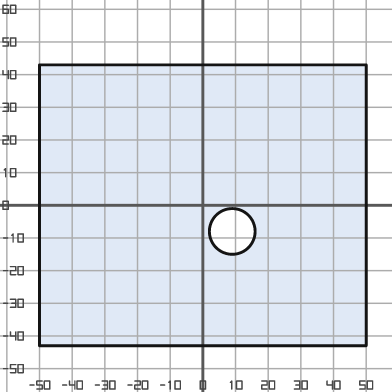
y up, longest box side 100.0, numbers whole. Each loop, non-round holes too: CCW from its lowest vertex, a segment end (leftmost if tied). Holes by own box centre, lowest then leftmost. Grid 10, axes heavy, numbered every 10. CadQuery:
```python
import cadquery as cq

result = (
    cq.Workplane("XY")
    .moveTo(-50.0, -43.0)
    .lineTo(50.0, -43.0)
    .lineTo(50.0, 43.0)
    .lineTo(-50.0, 43.0)
    .close()
    .moveTo(9.0, -8.0)
    .circle(7.0)
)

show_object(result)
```